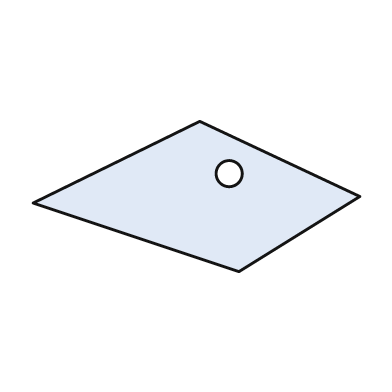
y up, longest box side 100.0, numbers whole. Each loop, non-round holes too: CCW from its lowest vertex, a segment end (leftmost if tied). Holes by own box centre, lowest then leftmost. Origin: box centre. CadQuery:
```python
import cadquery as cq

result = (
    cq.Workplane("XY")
    .moveTo(13.0, -23.0)
    .lineTo(50.0, 0.0)
    .lineTo(1.0, 23.0)
    .lineTo(-50.0, -2.0)
    .close()
    .moveTo(10.0, 7.0)
    .circle(4.0)
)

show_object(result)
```